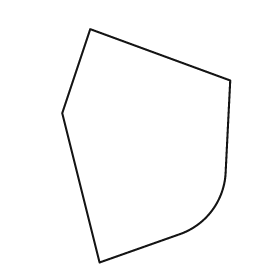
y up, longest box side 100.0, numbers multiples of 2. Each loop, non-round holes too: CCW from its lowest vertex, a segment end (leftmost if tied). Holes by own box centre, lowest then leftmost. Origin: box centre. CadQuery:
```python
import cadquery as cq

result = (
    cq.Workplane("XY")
    .moveTo(-20.0, -50.0)
    .lineTo(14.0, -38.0)
    .threePointArc((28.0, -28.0), (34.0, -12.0))
    .lineTo(36.0, 28.0)
    .lineTo(-24.0, 50.0)
    .lineTo(-36.0, 14.0)
    .close()
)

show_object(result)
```